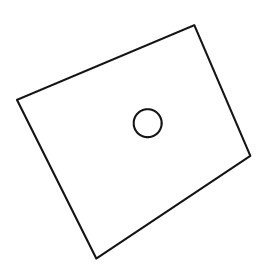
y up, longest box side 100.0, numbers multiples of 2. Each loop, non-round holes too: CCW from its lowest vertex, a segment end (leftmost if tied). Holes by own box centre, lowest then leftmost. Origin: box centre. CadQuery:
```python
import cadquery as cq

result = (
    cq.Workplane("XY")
    .moveTo(-16.0, -50.0)
    .lineTo(50.0, -6.0)
    .lineTo(26.0, 50.0)
    .lineTo(-50.0, 18.0)
    .close()
    .moveTo(6.0, 8.0)
    .circle(6.0)
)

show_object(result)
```